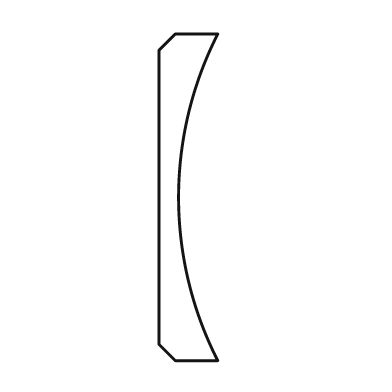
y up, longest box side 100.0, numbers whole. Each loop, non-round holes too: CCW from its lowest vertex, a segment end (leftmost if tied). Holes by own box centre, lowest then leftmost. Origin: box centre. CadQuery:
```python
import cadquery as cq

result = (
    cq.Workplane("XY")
    .moveTo(-4.0, -50.0)
    .lineTo(9.0, -50.0)
    .threePointArc((-3.0, 0.0), (9.0, 50.0))
    .lineTo(-4.0, 50.0)
    .lineTo(-9.0, 45.0)
    .lineTo(-9.0, -45.0)
    .close()
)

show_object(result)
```